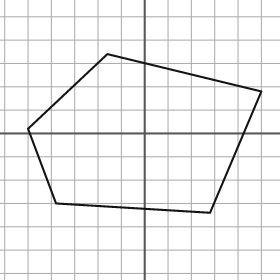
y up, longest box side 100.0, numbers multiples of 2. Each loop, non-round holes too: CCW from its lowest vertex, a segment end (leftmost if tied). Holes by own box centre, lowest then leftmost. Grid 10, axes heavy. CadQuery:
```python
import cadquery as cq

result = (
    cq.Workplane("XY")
    .moveTo(28.0, -34.0)
    .lineTo(50.0, 18.0)
    .lineTo(-16.0, 34.0)
    .lineTo(-50.0, 2.0)
    .lineTo(-38.0, -30.0)
    .close()
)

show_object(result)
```